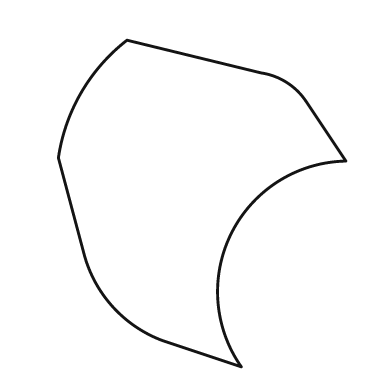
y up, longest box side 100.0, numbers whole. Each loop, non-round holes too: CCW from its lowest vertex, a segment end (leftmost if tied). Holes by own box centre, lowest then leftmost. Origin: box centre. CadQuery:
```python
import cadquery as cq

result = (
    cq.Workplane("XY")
    .moveTo(12.0, -50.0)
    .threePointArc((9.0, -9.0), (44.0, 13.0))
    .lineTo(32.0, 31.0)
    .threePointArc((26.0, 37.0), (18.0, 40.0))
    .lineTo(-23.0, 50.0)
    .threePointArc((-37.0, 34.0), (-44.0, 14.0))
    .lineTo(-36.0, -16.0)
    .threePointArc((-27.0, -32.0), (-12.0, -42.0))
    .close()
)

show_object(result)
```